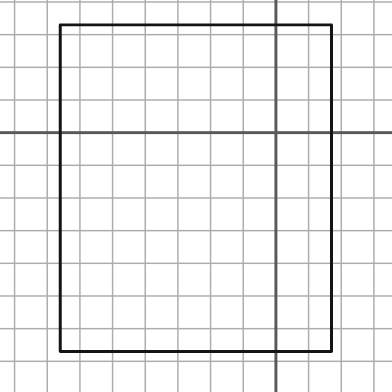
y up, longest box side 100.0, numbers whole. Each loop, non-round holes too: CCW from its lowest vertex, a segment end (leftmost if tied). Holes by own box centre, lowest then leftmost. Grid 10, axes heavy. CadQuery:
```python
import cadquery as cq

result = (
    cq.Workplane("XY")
    .moveTo(-66.0, -67.0)
    .lineTo(17.0, -67.0)
    .lineTo(17.0, 33.0)
    .lineTo(-66.0, 33.0)
    .close()
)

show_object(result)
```